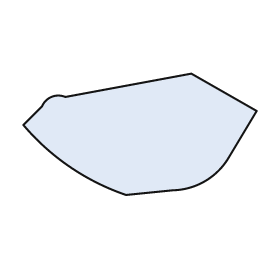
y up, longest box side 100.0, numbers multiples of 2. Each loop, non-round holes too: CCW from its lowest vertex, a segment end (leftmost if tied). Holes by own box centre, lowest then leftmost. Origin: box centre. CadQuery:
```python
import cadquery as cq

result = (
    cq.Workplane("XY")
    .moveTo(-6.0, -26.0)
    .lineTo(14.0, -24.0)
    .threePointArc((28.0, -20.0), (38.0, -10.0))
    .lineTo(50.0, 10.0)
    .lineTo(22.0, 26.0)
    .lineTo(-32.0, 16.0)
    .threePointArc((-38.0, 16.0), (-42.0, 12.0))
    .lineTo(-50.0, 4.0)
    .threePointArc((-30.0, -14.0), (-6.0, -26.0))
    .close()
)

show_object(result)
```